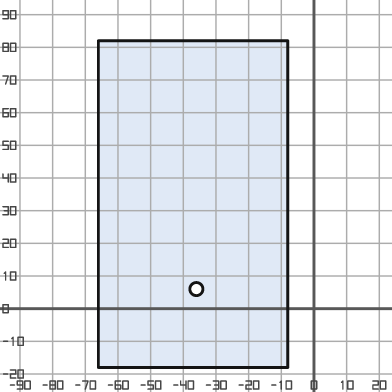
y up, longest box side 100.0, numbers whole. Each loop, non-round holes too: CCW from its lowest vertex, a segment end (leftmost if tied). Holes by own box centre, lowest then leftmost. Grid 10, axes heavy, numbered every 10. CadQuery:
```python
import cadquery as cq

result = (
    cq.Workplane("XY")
    .moveTo(-66.0, -18.0)
    .lineTo(-8.0, -18.0)
    .lineTo(-8.0, 82.0)
    .lineTo(-66.0, 82.0)
    .close()
    .moveTo(-36.0, 6.0)
    .circle(2.0)
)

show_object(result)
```